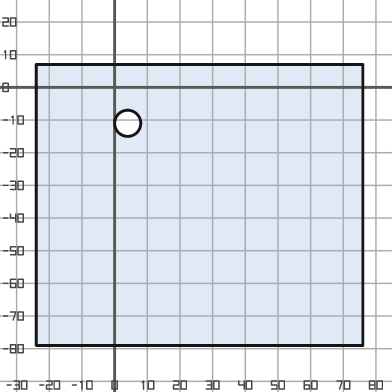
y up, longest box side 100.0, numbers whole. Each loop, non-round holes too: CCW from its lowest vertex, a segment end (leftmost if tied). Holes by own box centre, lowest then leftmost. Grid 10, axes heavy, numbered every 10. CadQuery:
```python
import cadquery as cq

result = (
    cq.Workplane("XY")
    .moveTo(-24.0, -79.0)
    .lineTo(76.0, -79.0)
    .lineTo(76.0, 7.0)
    .lineTo(-24.0, 7.0)
    .close()
    .moveTo(4.0, -11.0)
    .circle(4.0)
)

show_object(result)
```